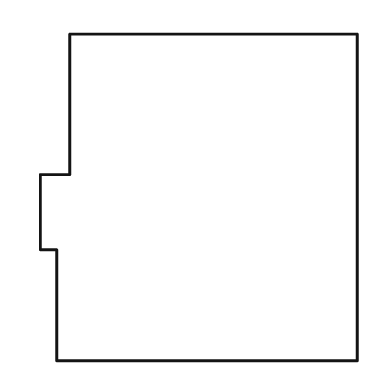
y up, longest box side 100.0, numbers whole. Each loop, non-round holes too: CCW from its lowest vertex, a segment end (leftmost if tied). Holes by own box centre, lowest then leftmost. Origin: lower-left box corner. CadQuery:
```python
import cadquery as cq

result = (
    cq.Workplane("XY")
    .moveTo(5.0, 0.0)
    .lineTo(97.0, 0.0)
    .lineTo(97.0, 100.0)
    .lineTo(9.0, 100.0)
    .lineTo(9.0, 57.0)
    .lineTo(0.0, 57.0)
    .lineTo(0.0, 34.0)
    .lineTo(5.0, 34.0)
    .close()
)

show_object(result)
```